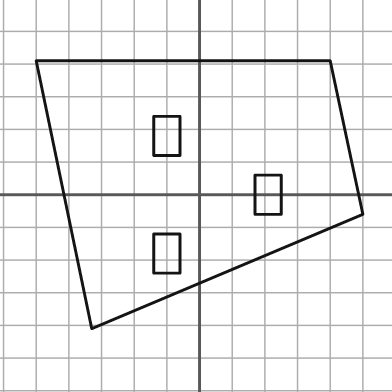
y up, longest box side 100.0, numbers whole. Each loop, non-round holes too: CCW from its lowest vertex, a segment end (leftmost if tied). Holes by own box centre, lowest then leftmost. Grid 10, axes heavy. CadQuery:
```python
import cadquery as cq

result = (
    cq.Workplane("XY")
    .moveTo(-33.0, -41.0)
    .lineTo(50.0, -6.0)
    .lineTo(40.0, 41.0)
    .lineTo(-50.0, 41.0)
    .close()
    .moveTo(-14.0, -24.0)
    .lineTo(-6.0, -24.0)
    .lineTo(-6.0, -12.0)
    .lineTo(-14.0, -12.0)
    .close()
    .moveTo(17.0, -6.0)
    .lineTo(25.0, -6.0)
    .lineTo(25.0, 6.0)
    .lineTo(17.0, 6.0)
    .close()
    .moveTo(-14.0, 12.0)
    .lineTo(-6.0, 12.0)
    .lineTo(-6.0, 24.0)
    .lineTo(-14.0, 24.0)
    .close()
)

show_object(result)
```